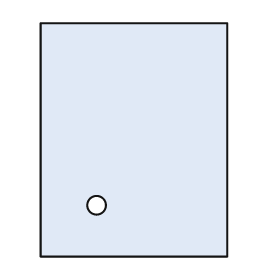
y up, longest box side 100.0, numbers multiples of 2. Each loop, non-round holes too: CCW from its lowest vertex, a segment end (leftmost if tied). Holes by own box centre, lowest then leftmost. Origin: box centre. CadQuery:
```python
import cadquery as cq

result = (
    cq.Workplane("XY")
    .moveTo(-40.0, -50.0)
    .lineTo(40.0, -50.0)
    .lineTo(40.0, 50.0)
    .lineTo(-40.0, 50.0)
    .close()
    .moveTo(-16.0, -28.0)
    .circle(4.0)
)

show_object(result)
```